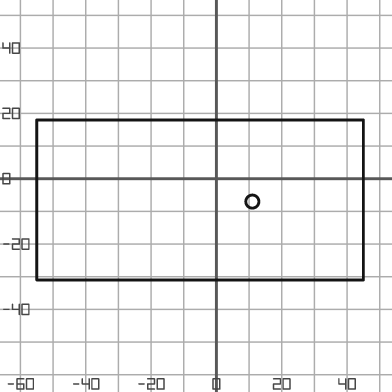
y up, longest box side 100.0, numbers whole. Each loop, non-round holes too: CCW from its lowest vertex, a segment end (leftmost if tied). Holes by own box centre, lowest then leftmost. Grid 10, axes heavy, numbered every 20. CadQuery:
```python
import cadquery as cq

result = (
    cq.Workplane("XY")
    .moveTo(-55.0, -31.0)
    .lineTo(45.0, -31.0)
    .lineTo(45.0, 18.0)
    .lineTo(-55.0, 18.0)
    .close()
    .moveTo(11.0, -7.0)
    .circle(2.0)
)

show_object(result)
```